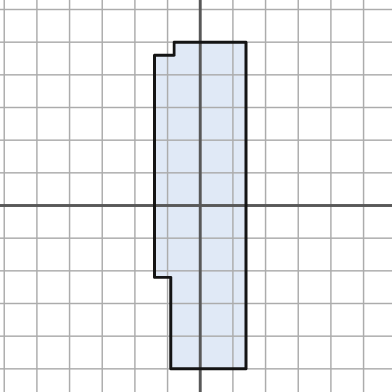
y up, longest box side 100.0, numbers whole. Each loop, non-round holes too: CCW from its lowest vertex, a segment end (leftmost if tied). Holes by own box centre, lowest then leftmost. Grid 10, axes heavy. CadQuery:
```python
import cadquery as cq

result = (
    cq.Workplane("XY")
    .moveTo(-9.0, -50.0)
    .lineTo(14.0, -50.0)
    .lineTo(14.0, 50.0)
    .lineTo(-8.0, 50.0)
    .lineTo(-8.0, 46.0)
    .lineTo(-14.0, 46.0)
    .lineTo(-14.0, -22.0)
    .lineTo(-9.0, -22.0)
    .close()
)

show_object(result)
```